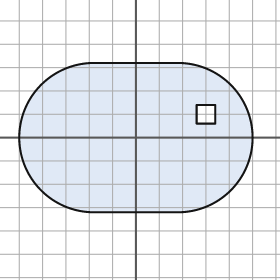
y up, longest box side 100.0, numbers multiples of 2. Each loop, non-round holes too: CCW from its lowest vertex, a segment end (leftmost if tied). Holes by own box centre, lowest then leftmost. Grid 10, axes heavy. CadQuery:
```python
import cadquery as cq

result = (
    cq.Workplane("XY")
    .moveTo(-18.0, -32.0)
    .lineTo(18.0, -32.0)
    .threePointArc((50.0, 0.0), (18.0, 32.0))
    .lineTo(-18.0, 32.0)
    .threePointArc((-50.0, 0.0), (-18.0, -32.0))
    .close()
    .moveTo(26.0, 6.0)
    .lineTo(34.0, 6.0)
    .lineTo(34.0, 14.0)
    .lineTo(26.0, 14.0)
    .close()
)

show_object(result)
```